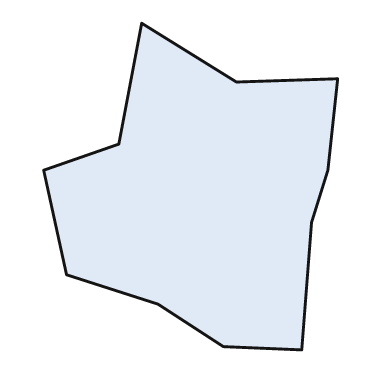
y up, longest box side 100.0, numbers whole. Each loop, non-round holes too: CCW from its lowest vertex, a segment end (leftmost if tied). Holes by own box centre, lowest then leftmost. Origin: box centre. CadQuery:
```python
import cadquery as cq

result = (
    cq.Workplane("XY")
    .moveTo(34.0, -50.0)
    .lineTo(37.0, -11.0)
    .lineTo(42.0, 5.0)
    .lineTo(45.0, 33.0)
    .lineTo(14.0, 32.0)
    .lineTo(-15.0, 50.0)
    .lineTo(-22.0, 13.0)
    .lineTo(-45.0, 5.0)
    .lineTo(-38.0, -27.0)
    .lineTo(-10.0, -36.0)
    .lineTo(10.0, -49.0)
    .close()
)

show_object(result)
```